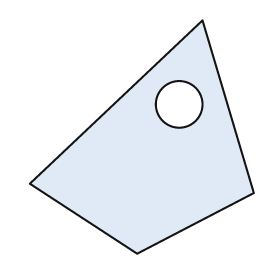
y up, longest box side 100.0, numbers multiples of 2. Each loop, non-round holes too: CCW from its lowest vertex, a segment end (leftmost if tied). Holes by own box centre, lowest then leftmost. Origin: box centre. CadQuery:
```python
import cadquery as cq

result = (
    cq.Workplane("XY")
    .moveTo(-2.0, -50.0)
    .lineTo(48.0, -24.0)
    .lineTo(26.0, 50.0)
    .lineTo(-48.0, -20.0)
    .close()
    .moveTo(16.0, 14.0)
    .circle(10.0)
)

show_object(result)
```